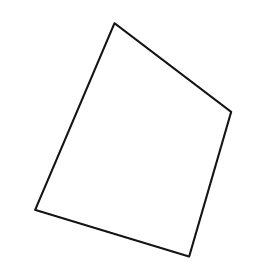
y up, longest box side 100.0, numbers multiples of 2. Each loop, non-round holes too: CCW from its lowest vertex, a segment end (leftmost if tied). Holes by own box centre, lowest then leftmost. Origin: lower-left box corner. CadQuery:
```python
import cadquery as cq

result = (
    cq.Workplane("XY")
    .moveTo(66.0, 0.0)
    .lineTo(84.0, 62.0)
    .lineTo(34.0, 100.0)
    .lineTo(0.0, 20.0)
    .close()
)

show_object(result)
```